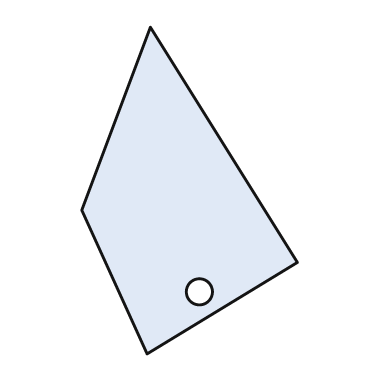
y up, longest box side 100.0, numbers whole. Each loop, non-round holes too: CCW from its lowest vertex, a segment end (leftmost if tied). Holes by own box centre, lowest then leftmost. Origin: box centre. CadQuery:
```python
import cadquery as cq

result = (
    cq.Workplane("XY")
    .moveTo(-13.0, -50.0)
    .lineTo(33.0, -22.0)
    .lineTo(-12.0, 50.0)
    .lineTo(-33.0, -6.0)
    .close()
    .moveTo(3.0, -31.0)
    .circle(4.0)
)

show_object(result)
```